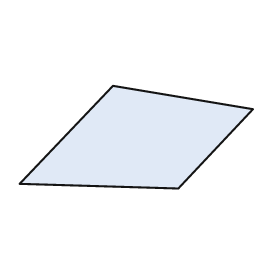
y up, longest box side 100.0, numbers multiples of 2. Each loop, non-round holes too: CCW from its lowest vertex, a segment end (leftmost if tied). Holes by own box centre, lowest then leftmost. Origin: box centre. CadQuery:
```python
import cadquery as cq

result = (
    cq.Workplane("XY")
    .moveTo(18.0, -22.0)
    .lineTo(50.0, 12.0)
    .lineTo(-10.0, 22.0)
    .lineTo(-50.0, -20.0)
    .close()
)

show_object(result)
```